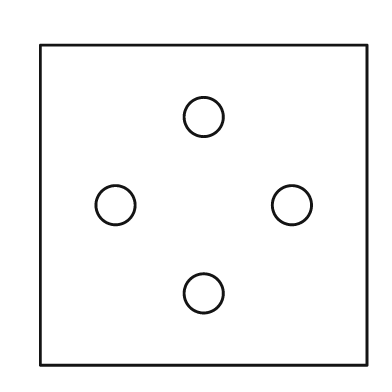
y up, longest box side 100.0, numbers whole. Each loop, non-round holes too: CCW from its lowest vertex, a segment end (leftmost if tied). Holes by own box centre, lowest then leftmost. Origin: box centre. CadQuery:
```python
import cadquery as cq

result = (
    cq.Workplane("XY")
    .moveTo(-50.0, -49.0)
    .lineTo(50.0, -49.0)
    .lineTo(50.0, 49.0)
    .lineTo(-50.0, 49.0)
    .close()
    .moveTo(0.0, -27.0)
    .circle(6.0)
    .moveTo(-27.0, 0.0)
    .circle(6.0)
    .moveTo(27.0, 0.0)
    .circle(6.0)
    .moveTo(0.0, 27.0)
    .circle(6.0)
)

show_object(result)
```